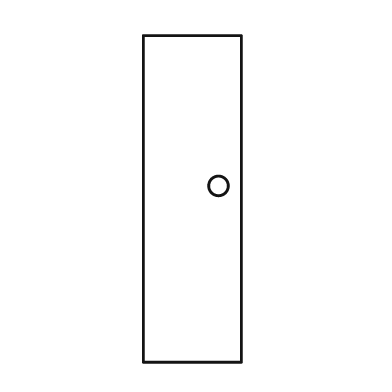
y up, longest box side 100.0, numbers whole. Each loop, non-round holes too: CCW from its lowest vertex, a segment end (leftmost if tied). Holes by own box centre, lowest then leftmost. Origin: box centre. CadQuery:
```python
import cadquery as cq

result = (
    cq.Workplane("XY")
    .moveTo(-15.0, -50.0)
    .lineTo(15.0, -50.0)
    .lineTo(15.0, 50.0)
    .lineTo(-15.0, 50.0)
    .close()
    .moveTo(8.0, 4.0)
    .circle(3.0)
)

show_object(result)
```